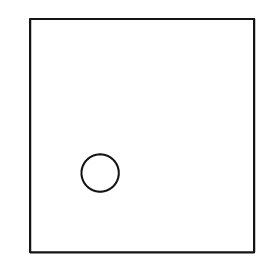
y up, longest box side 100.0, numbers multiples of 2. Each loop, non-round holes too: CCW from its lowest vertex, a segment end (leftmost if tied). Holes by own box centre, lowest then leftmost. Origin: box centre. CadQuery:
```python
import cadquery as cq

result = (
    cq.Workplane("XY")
    .moveTo(-48.0, -50.0)
    .lineTo(48.0, -50.0)
    .lineTo(48.0, 50.0)
    .lineTo(-48.0, 50.0)
    .close()
    .moveTo(-18.0, -16.0)
    .circle(8.0)
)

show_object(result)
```